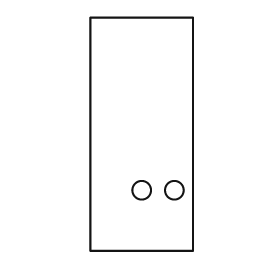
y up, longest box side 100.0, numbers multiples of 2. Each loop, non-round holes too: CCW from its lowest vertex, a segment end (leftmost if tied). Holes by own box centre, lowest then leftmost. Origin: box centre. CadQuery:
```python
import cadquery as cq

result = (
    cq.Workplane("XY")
    .moveTo(-22.0, -50.0)
    .lineTo(22.0, -50.0)
    .lineTo(22.0, 50.0)
    .lineTo(-22.0, 50.0)
    .close()
    .moveTo(0.0, -24.0)
    .circle(4.0)
    .moveTo(14.0, -24.0)
    .circle(4.0)
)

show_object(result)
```